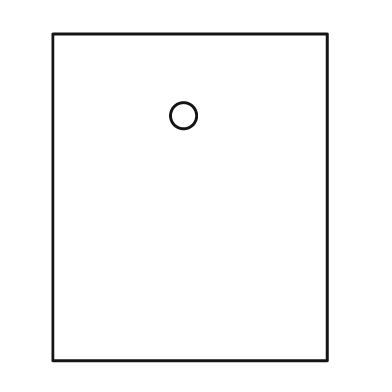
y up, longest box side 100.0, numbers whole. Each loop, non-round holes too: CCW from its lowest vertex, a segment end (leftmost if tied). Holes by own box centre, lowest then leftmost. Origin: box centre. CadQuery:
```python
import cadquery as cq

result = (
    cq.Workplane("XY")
    .moveTo(-42.0, -50.0)
    .lineTo(42.0, -50.0)
    .lineTo(42.0, 50.0)
    .lineTo(-42.0, 50.0)
    .close()
    .moveTo(-2.0, 25.0)
    .circle(4.0)
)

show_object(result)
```